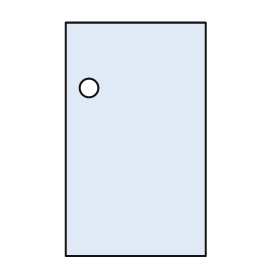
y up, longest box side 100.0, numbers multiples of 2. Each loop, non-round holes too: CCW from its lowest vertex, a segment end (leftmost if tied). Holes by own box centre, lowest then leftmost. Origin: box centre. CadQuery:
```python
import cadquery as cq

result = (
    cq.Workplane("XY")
    .moveTo(-30.0, -50.0)
    .lineTo(30.0, -50.0)
    .lineTo(30.0, 50.0)
    .lineTo(-30.0, 50.0)
    .close()
    .moveTo(-20.0, 22.0)
    .circle(4.0)
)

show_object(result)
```